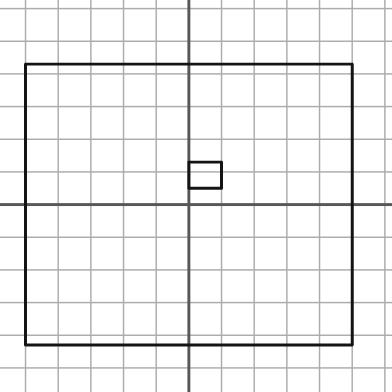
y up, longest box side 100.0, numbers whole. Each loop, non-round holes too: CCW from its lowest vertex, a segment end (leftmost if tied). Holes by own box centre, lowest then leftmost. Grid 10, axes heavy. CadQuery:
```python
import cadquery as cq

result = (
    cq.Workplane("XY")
    .moveTo(-50.0, -43.0)
    .lineTo(50.0, -43.0)
    .lineTo(50.0, 43.0)
    .lineTo(-50.0, 43.0)
    .close()
    .moveTo(0.0, 5.0)
    .lineTo(10.0, 5.0)
    .lineTo(10.0, 13.0)
    .lineTo(0.0, 13.0)
    .close()
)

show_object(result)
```